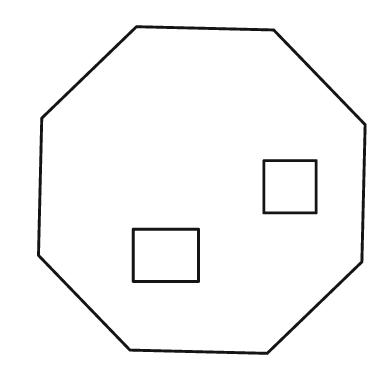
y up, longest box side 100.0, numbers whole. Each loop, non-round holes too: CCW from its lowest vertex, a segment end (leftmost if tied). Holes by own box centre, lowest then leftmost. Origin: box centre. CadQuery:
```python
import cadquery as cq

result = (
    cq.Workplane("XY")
    .moveTo(20.0, -50.0)
    .lineTo(49.0, -22.0)
    .lineTo(50.0, 20.0)
    .lineTo(22.0, 49.0)
    .lineTo(-20.0, 50.0)
    .lineTo(-49.0, 22.0)
    .lineTo(-50.0, -20.0)
    .lineTo(-22.0, -49.0)
    .close()
    .moveTo(-21.0, -28.0)
    .lineTo(-1.0, -28.0)
    .lineTo(-1.0, -12.0)
    .lineTo(-21.0, -12.0)
    .close()
    .moveTo(19.0, -7.0)
    .lineTo(35.0, -7.0)
    .lineTo(35.0, 9.0)
    .lineTo(19.0, 9.0)
    .close()
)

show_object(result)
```